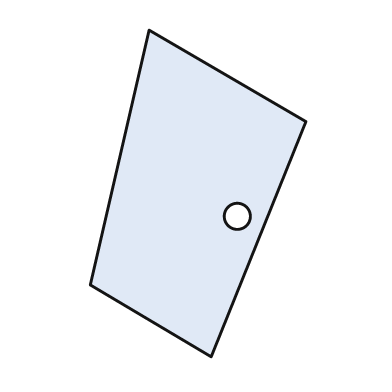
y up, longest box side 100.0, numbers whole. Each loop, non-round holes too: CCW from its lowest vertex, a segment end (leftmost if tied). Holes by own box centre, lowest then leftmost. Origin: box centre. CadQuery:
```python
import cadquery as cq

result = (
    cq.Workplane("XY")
    .moveTo(4.0, -50.0)
    .lineTo(33.0, 22.0)
    .lineTo(-15.0, 50.0)
    .lineTo(-33.0, -28.0)
    .close()
    .moveTo(12.0, -7.0)
    .circle(4.0)
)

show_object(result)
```